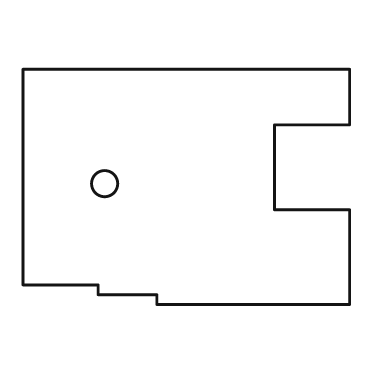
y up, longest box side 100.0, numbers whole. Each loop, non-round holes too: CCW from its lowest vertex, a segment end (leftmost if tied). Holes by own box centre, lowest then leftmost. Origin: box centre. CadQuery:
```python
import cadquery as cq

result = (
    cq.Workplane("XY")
    .moveTo(-9.0, -36.0)
    .lineTo(50.0, -36.0)
    .lineTo(50.0, -7.0)
    .lineTo(27.0, -7.0)
    .lineTo(27.0, 19.0)
    .lineTo(50.0, 19.0)
    .lineTo(50.0, 36.0)
    .lineTo(-50.0, 36.0)
    .lineTo(-50.0, -30.0)
    .lineTo(-27.0, -30.0)
    .lineTo(-27.0, -33.0)
    .lineTo(-9.0, -33.0)
    .close()
    .moveTo(-25.0, 1.0)
    .circle(4.0)
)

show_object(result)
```